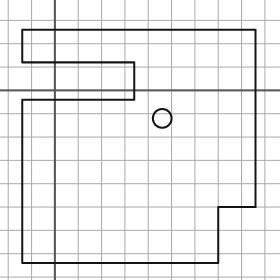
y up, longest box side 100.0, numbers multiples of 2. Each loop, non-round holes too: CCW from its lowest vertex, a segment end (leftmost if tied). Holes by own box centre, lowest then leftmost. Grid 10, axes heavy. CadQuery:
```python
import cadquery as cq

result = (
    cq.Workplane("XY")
    .moveTo(-14.0, -74.0)
    .lineTo(70.0, -74.0)
    .lineTo(70.0, -50.0)
    .lineTo(86.0, -50.0)
    .lineTo(86.0, 26.0)
    .lineTo(-14.0, 26.0)
    .lineTo(-14.0, 12.0)
    .lineTo(34.0, 12.0)
    .lineTo(34.0, -4.0)
    .lineTo(-14.0, -4.0)
    .close()
    .moveTo(46.0, -12.0)
    .circle(4.0)
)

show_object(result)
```